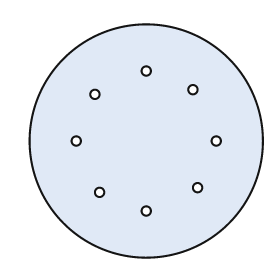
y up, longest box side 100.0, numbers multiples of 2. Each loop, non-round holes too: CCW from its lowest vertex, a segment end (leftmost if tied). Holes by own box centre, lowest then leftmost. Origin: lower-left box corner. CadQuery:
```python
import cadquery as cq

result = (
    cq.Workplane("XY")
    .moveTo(50.0, 50.0)
    .circle(50.0)
    .moveTo(50.0, 20.0)
    .circle(2.0)
    .moveTo(30.0, 28.0)
    .circle(2.0)
    .moveTo(72.0, 30.0)
    .circle(2.0)
    .moveTo(20.0, 50.0)
    .circle(2.0)
    .moveTo(80.0, 50.0)
    .circle(2.0)
    .moveTo(28.0, 70.0)
    .circle(2.0)
    .moveTo(70.0, 72.0)
    .circle(2.0)
    .moveTo(50.0, 80.0)
    .circle(2.0)
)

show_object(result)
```